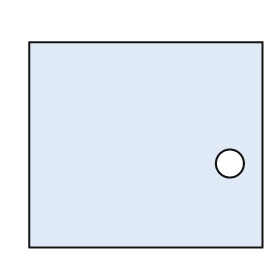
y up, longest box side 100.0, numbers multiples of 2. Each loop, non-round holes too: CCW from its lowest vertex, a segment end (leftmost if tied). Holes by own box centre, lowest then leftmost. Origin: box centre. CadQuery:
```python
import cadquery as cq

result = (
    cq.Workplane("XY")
    .moveTo(-50.0, -44.0)
    .lineTo(50.0, -44.0)
    .lineTo(50.0, 44.0)
    .lineTo(-50.0, 44.0)
    .close()
    .moveTo(36.0, -8.0)
    .circle(6.0)
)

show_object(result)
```